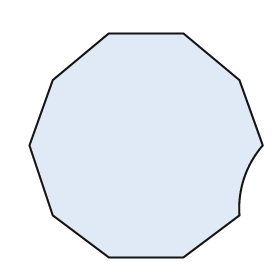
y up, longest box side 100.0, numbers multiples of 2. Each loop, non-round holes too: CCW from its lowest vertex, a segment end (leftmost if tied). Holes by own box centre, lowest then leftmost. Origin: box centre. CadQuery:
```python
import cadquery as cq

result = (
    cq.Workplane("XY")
    .moveTo(-16.0, -48.0)
    .lineTo(16.0, -48.0)
    .lineTo(40.0, -30.0)
    .threePointArc((42.0, -14.0), (50.0, 0.0))
    .lineTo(40.0, 28.0)
    .lineTo(16.0, 48.0)
    .lineTo(-16.0, 48.0)
    .lineTo(-40.0, 28.0)
    .lineTo(-50.0, 0.0)
    .lineTo(-40.0, -30.0)
    .close()
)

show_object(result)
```